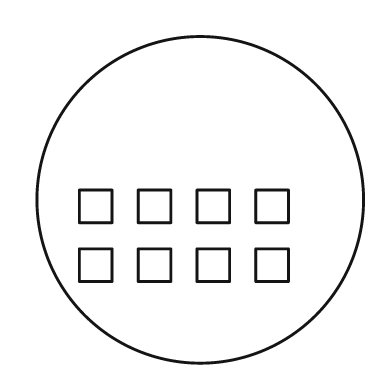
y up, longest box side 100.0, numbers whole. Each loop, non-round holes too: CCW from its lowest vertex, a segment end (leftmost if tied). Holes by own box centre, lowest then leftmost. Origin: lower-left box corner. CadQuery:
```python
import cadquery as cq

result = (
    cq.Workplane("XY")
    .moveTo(50.0, 50.0)
    .circle(50.0)
    .moveTo(13.0, 25.0)
    .lineTo(23.0, 25.0)
    .lineTo(23.0, 35.0)
    .lineTo(13.0, 35.0)
    .close()
    .moveTo(31.0, 25.0)
    .lineTo(41.0, 25.0)
    .lineTo(41.0, 35.0)
    .lineTo(31.0, 35.0)
    .close()
    .moveTo(49.0, 25.0)
    .lineTo(59.0, 25.0)
    .lineTo(59.0, 35.0)
    .lineTo(49.0, 35.0)
    .close()
    .moveTo(67.0, 25.0)
    .lineTo(77.0, 25.0)
    .lineTo(77.0, 35.0)
    .lineTo(67.0, 35.0)
    .close()
    .moveTo(13.0, 43.0)
    .lineTo(23.0, 43.0)
    .lineTo(23.0, 53.0)
    .lineTo(13.0, 53.0)
    .close()
    .moveTo(31.0, 43.0)
    .lineTo(41.0, 43.0)
    .lineTo(41.0, 53.0)
    .lineTo(31.0, 53.0)
    .close()
    .moveTo(49.0, 43.0)
    .lineTo(59.0, 43.0)
    .lineTo(59.0, 53.0)
    .lineTo(49.0, 53.0)
    .close()
    .moveTo(67.0, 43.0)
    .lineTo(77.0, 43.0)
    .lineTo(77.0, 53.0)
    .lineTo(67.0, 53.0)
    .close()
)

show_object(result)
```